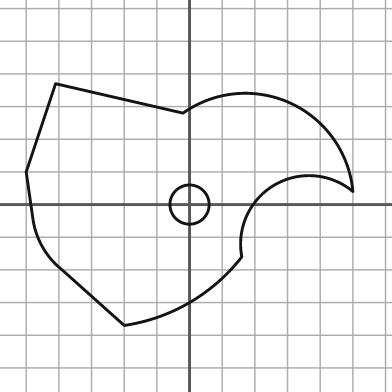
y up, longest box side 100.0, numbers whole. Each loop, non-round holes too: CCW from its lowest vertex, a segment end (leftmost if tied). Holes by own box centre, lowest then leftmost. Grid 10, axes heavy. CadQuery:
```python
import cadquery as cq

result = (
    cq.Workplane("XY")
    .moveTo(-20.0, -37.0)
    .threePointArc((0.0, -30.0), (16.0, -16.0))
    .threePointArc((26.0, 6.0), (50.0, 4.0))
    .threePointArc((31.0, 31.0), (-2.0, 28.0))
    .lineTo(-41.0, 37.0)
    .lineTo(-50.0, 10.0)
    .lineTo(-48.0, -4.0)
    .threePointArc((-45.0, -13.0), (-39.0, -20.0))
    .close()
    .moveTo(0.0, 0.0)
    .circle(6.0)
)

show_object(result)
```